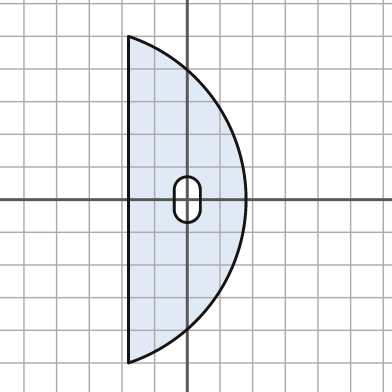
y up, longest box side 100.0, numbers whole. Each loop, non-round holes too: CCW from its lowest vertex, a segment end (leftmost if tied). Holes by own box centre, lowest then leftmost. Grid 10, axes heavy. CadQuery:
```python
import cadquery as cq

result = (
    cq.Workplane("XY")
    .moveTo(-18.0, -50.0)
    .threePointArc((18.0, 0.0), (-18.0, 50.0))
    .close()
    .moveTo(-4.0, -3.0)
    .threePointArc((0.0, -7.0), (4.0, -3.0))
    .lineTo(4.0, 3.0)
    .threePointArc((0.0, 7.0), (-4.0, 3.0))
    .close()
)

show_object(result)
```